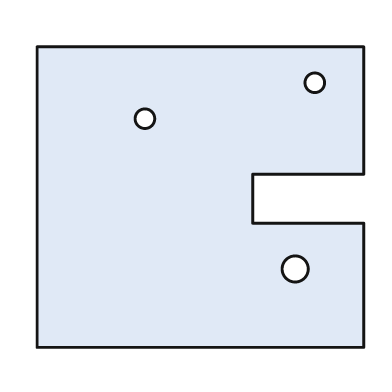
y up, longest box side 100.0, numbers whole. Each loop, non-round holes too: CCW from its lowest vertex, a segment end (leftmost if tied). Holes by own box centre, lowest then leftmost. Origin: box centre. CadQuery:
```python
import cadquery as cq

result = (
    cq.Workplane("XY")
    .moveTo(-50.0, -46.0)
    .lineTo(50.0, -46.0)
    .lineTo(50.0, -8.0)
    .lineTo(16.0, -8.0)
    .lineTo(16.0, 7.0)
    .lineTo(50.0, 7.0)
    .lineTo(50.0, 46.0)
    .lineTo(-50.0, 46.0)
    .close()
    .moveTo(29.0, -22.0)
    .circle(4.0)
    .moveTo(-17.0, 24.0)
    .circle(3.0)
    .moveTo(35.0, 35.0)
    .circle(3.0)
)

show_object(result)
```